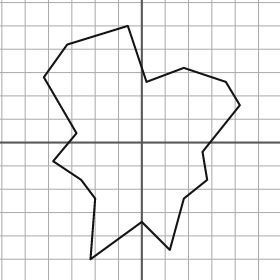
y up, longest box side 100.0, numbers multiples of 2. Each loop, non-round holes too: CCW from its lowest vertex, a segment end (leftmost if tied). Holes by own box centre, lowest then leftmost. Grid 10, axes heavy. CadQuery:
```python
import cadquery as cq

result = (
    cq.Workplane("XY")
    .moveTo(-22.0, -50.0)
    .lineTo(0.0, -34.0)
    .lineTo(12.0, -46.0)
    .lineTo(18.0, -24.0)
    .lineTo(28.0, -16.0)
    .lineTo(26.0, -4.0)
    .lineTo(42.0, 16.0)
    .lineTo(36.0, 26.0)
    .lineTo(18.0, 32.0)
    .lineTo(2.0, 26.0)
    .lineTo(-6.0, 50.0)
    .lineTo(-32.0, 42.0)
    .lineTo(-42.0, 28.0)
    .lineTo(-28.0, 4.0)
    .lineTo(-38.0, -8.0)
    .lineTo(-26.0, -16.0)
    .lineTo(-20.0, -24.0)
    .close()
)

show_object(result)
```